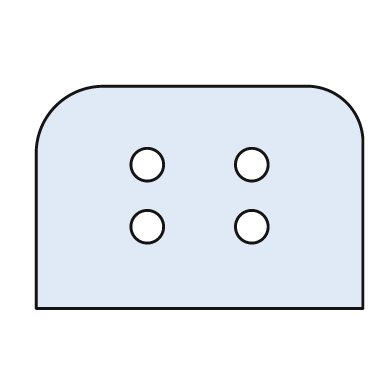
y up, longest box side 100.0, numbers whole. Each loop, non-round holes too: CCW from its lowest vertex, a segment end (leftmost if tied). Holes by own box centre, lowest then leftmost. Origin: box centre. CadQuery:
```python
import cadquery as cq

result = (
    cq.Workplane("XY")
    .moveTo(-50.0, -34.0)
    .lineTo(50.0, -34.0)
    .lineTo(50.0, 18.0)
    .threePointArc((45.0, 29.0), (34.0, 34.0))
    .lineTo(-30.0, 34.0)
    .threePointArc((-44.0, 28.0), (-50.0, 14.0))
    .close()
    .moveTo(-16.0, -9.0)
    .circle(5.0)
    .moveTo(16.0, -9.0)
    .circle(5.0)
    .moveTo(-16.0, 10.0)
    .circle(5.0)
    .moveTo(16.0, 10.0)
    .circle(5.0)
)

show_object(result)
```